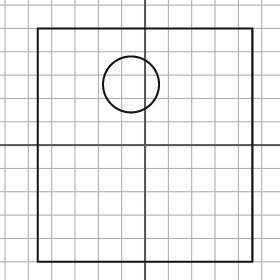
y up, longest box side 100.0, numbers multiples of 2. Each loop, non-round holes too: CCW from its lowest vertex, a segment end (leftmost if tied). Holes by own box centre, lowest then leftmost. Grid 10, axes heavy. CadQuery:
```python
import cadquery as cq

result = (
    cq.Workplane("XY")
    .moveTo(-46.0, -50.0)
    .lineTo(46.0, -50.0)
    .lineTo(46.0, 50.0)
    .lineTo(-46.0, 50.0)
    .close()
    .moveTo(-6.0, 26.0)
    .circle(12.0)
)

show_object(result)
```